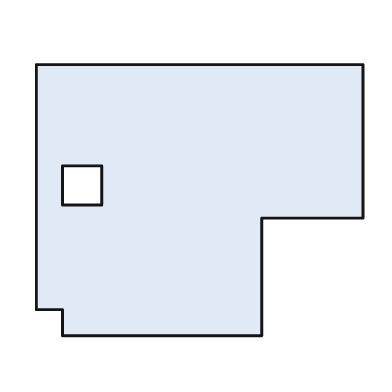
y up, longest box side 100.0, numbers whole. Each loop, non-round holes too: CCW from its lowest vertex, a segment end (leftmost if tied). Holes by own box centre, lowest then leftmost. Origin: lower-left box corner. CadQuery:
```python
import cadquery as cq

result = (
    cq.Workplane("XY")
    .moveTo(8.0, 0.0)
    .lineTo(69.0, 0.0)
    .lineTo(69.0, 36.0)
    .lineTo(100.0, 36.0)
    .lineTo(100.0, 83.0)
    .lineTo(0.0, 83.0)
    .lineTo(0.0, 8.0)
    .lineTo(8.0, 8.0)
    .close()
    .moveTo(8.0, 40.0)
    .lineTo(20.0, 40.0)
    .lineTo(20.0, 52.0)
    .lineTo(8.0, 52.0)
    .close()
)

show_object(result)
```